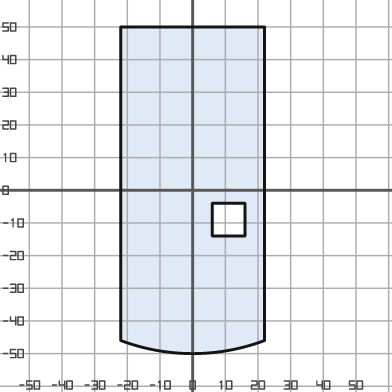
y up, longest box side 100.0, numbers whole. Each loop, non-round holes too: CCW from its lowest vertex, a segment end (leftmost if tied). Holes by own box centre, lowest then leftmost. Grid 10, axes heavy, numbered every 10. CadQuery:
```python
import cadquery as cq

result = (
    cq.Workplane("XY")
    .moveTo(-22.0, -46.0)
    .threePointArc((0.0, -50.0), (22.0, -46.0))
    .lineTo(22.0, 50.0)
    .lineTo(-22.0, 50.0)
    .close()
    .moveTo(6.0, -14.0)
    .lineTo(16.0, -14.0)
    .lineTo(16.0, -4.0)
    .lineTo(6.0, -4.0)
    .close()
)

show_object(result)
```